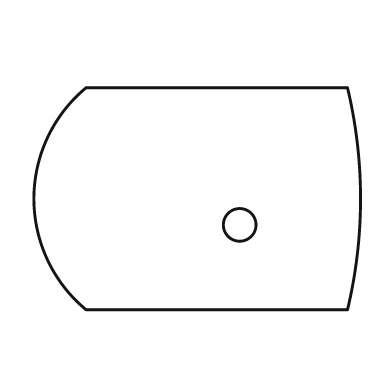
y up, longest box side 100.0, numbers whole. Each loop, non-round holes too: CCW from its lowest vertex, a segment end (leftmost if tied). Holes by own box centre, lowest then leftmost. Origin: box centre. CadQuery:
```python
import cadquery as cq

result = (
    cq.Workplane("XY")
    .moveTo(-34.0, -34.0)
    .lineTo(46.0, -34.0)
    .threePointArc((50.0, 0.0), (46.0, 34.0))
    .lineTo(-34.0, 34.0)
    .threePointArc((-50.0, 0.0), (-34.0, -34.0))
    .close()
    .moveTo(13.0, -8.0)
    .circle(5.0)
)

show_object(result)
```